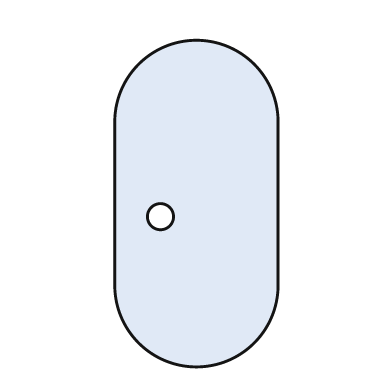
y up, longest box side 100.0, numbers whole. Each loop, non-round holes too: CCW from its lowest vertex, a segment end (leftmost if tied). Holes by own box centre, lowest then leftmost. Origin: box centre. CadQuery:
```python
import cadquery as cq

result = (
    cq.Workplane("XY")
    .moveTo(-25.0, -25.0)
    .threePointArc((0.0, -50.0), (25.0, -25.0))
    .lineTo(25.0, 25.0)
    .threePointArc((0.0, 50.0), (-25.0, 25.0))
    .close()
    .moveTo(-11.0, -4.0)
    .circle(4.0)
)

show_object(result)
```